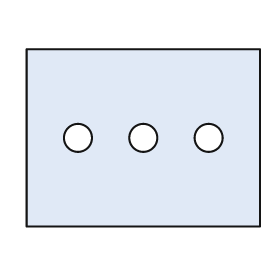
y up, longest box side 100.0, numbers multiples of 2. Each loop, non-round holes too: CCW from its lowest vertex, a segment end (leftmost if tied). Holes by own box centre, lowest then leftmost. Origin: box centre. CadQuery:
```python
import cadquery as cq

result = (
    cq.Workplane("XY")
    .moveTo(-50.0, -38.0)
    .lineTo(50.0, -38.0)
    .lineTo(50.0, 38.0)
    .lineTo(-50.0, 38.0)
    .close()
    .moveTo(-28.0, 0.0)
    .circle(6.0)
    .moveTo(0.0, 0.0)
    .circle(6.0)
    .moveTo(28.0, 0.0)
    .circle(6.0)
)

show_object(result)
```